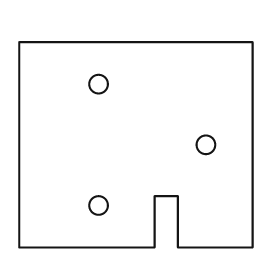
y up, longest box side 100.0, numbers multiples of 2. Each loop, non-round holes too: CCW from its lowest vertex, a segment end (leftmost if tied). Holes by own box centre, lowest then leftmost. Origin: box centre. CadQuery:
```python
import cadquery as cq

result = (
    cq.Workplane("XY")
    .moveTo(-50.0, -44.0)
    .lineTo(8.0, -44.0)
    .lineTo(8.0, -22.0)
    .lineTo(18.0, -22.0)
    .lineTo(18.0, -44.0)
    .lineTo(50.0, -44.0)
    .lineTo(50.0, 44.0)
    .lineTo(-50.0, 44.0)
    .close()
    .moveTo(-16.0, -26.0)
    .circle(4.0)
    .moveTo(30.0, 0.0)
    .circle(4.0)
    .moveTo(-16.0, 26.0)
    .circle(4.0)
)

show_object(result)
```